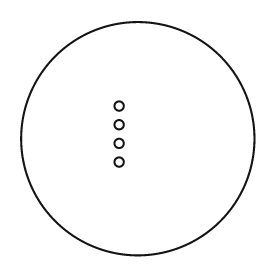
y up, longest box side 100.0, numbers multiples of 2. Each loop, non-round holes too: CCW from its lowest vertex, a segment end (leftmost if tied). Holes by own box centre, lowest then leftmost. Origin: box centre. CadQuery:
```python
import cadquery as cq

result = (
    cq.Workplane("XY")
    .moveTo(0.0, 0.0)
    .circle(50.0)
    .moveTo(-8.0, -10.0)
    .circle(2.0)
    .moveTo(-8.0, -2.0)
    .circle(2.0)
    .moveTo(-8.0, 6.0)
    .circle(2.0)
    .moveTo(-8.0, 14.0)
    .circle(2.0)
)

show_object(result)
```